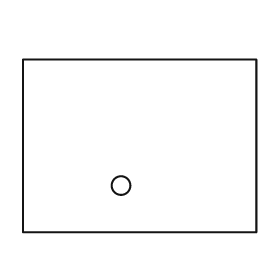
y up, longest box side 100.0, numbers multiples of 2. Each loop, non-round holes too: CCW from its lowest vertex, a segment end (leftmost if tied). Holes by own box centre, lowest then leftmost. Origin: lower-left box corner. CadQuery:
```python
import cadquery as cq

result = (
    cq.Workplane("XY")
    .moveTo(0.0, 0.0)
    .lineTo(100.0, 0.0)
    .lineTo(100.0, 74.0)
    .lineTo(0.0, 74.0)
    .close()
    .moveTo(42.0, 20.0)
    .circle(4.0)
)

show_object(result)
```